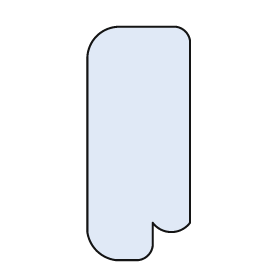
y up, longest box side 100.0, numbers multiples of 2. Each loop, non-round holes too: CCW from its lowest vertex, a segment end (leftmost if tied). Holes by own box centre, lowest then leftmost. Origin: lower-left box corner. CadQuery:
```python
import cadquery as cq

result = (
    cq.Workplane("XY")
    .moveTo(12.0, 0.0)
    .lineTo(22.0, 0.0)
    .threePointArc((26.0, 2.0), (28.0, 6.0))
    .lineTo(28.0, 16.0)
    .threePointArc((36.0, 12.0), (44.0, 16.0))
    .lineTo(44.0, 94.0)
    .threePointArc((42.0, 98.0), (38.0, 100.0))
    .lineTo(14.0, 100.0)
    .threePointArc((4.0, 96.0), (0.0, 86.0))
    .lineTo(0.0, 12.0)
    .threePointArc((4.0, 4.0), (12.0, 0.0))
    .close()
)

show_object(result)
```